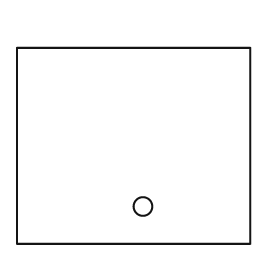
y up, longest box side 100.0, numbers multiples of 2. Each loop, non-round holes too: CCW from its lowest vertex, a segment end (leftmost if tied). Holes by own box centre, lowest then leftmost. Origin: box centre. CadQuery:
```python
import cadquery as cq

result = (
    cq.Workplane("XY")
    .moveTo(-50.0, -42.0)
    .lineTo(50.0, -42.0)
    .lineTo(50.0, 42.0)
    .lineTo(-50.0, 42.0)
    .close()
    .moveTo(4.0, -26.0)
    .circle(4.0)
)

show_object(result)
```